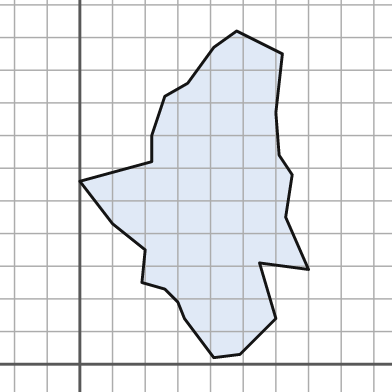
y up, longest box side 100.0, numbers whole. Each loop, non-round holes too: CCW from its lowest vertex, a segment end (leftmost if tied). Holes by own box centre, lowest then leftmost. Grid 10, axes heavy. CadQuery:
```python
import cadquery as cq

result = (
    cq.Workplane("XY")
    .moveTo(41.0, 2.0)
    .lineTo(49.0, 3.0)
    .lineTo(60.0, 14.0)
    .lineTo(55.0, 31.0)
    .lineTo(70.0, 29.0)
    .lineTo(63.0, 45.0)
    .lineTo(65.0, 58.0)
    .lineTo(61.0, 64.0)
    .lineTo(60.0, 77.0)
    .lineTo(62.0, 95.0)
    .lineTo(48.0, 102.0)
    .lineTo(41.0, 97.0)
    .lineTo(33.0, 86.0)
    .lineTo(26.0, 82.0)
    .lineTo(22.0, 70.0)
    .lineTo(22.0, 62.0)
    .lineTo(0.0, 56.0)
    .lineTo(10.0, 43.0)
    .lineTo(20.0, 35.0)
    .lineTo(19.0, 25.0)
    .lineTo(26.0, 23.0)
    .lineTo(30.0, 19.0)
    .lineTo(32.0, 14.0)
    .close()
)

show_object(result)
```